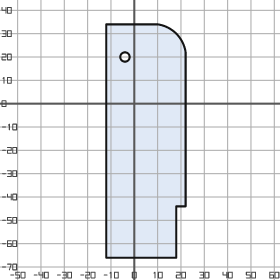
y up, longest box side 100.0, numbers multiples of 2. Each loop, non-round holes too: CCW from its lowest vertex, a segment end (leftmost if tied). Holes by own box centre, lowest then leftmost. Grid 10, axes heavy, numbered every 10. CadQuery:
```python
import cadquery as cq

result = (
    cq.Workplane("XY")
    .moveTo(-12.0, -66.0)
    .lineTo(18.0, -66.0)
    .lineTo(18.0, -44.0)
    .lineTo(22.0, -44.0)
    .lineTo(22.0, 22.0)
    .threePointArc((18.0, 30.0), (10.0, 34.0))
    .lineTo(-12.0, 34.0)
    .close()
    .moveTo(-4.0, 20.0)
    .circle(2.0)
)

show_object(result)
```